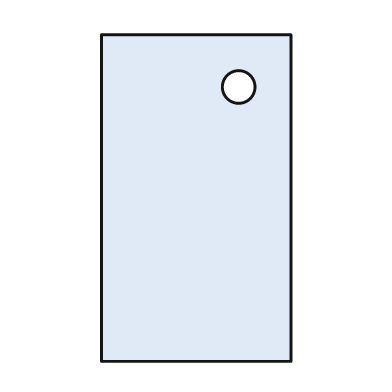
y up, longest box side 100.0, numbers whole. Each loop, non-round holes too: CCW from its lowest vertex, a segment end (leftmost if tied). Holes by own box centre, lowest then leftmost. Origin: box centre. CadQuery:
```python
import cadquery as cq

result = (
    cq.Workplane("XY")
    .moveTo(-29.0, -50.0)
    .lineTo(29.0, -50.0)
    .lineTo(29.0, 50.0)
    .lineTo(-29.0, 50.0)
    .close()
    .moveTo(13.0, 34.0)
    .circle(5.0)
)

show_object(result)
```